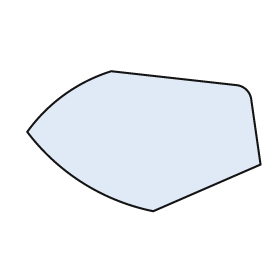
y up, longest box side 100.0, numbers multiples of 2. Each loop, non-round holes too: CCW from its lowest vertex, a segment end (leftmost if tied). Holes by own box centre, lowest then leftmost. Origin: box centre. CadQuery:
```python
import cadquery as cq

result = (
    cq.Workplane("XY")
    .moveTo(4.0, -30.0)
    .lineTo(50.0, -10.0)
    .lineTo(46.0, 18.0)
    .threePointArc((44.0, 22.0), (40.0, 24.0))
    .lineTo(-14.0, 30.0)
    .threePointArc((-34.0, 20.0), (-50.0, 4.0))
    .threePointArc((-26.0, -18.0), (4.0, -30.0))
    .close()
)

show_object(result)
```